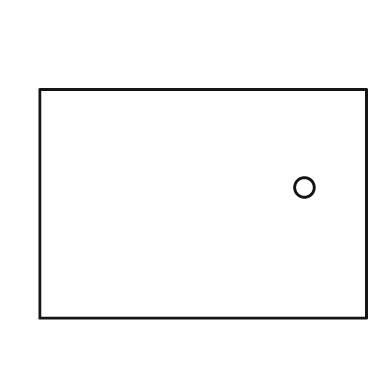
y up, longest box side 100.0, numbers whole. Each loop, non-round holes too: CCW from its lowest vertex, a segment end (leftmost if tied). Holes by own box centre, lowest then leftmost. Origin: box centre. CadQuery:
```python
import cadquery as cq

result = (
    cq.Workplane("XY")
    .moveTo(-50.0, -35.0)
    .lineTo(50.0, -35.0)
    .lineTo(50.0, 35.0)
    .lineTo(-50.0, 35.0)
    .close()
    .moveTo(31.0, 5.0)
    .circle(3.0)
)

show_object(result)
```